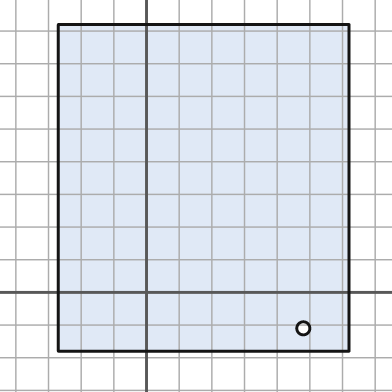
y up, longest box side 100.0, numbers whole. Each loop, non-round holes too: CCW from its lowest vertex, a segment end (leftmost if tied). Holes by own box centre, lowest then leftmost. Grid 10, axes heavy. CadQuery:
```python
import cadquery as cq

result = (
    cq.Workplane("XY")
    .moveTo(-27.0, -18.0)
    .lineTo(62.0, -18.0)
    .lineTo(62.0, 82.0)
    .lineTo(-27.0, 82.0)
    .close()
    .moveTo(48.0, -11.0)
    .circle(2.0)
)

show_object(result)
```